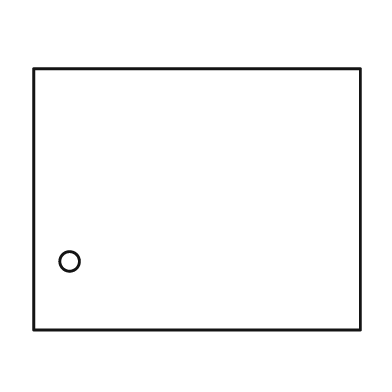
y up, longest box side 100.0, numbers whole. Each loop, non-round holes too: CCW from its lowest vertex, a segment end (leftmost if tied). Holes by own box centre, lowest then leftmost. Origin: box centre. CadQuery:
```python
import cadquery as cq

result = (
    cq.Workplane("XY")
    .moveTo(-50.0, -40.0)
    .lineTo(50.0, -40.0)
    .lineTo(50.0, 40.0)
    .lineTo(-50.0, 40.0)
    .close()
    .moveTo(-39.0, -19.0)
    .circle(3.0)
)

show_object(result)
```